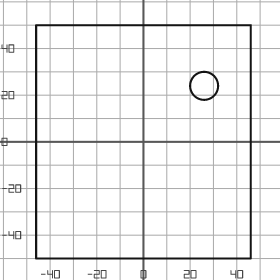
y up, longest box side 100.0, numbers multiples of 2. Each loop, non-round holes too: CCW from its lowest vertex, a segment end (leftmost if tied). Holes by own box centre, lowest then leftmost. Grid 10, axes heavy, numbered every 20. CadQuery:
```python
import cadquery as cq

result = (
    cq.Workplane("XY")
    .moveTo(-46.0, -50.0)
    .lineTo(46.0, -50.0)
    .lineTo(46.0, 50.0)
    .lineTo(-46.0, 50.0)
    .close()
    .moveTo(26.0, 24.0)
    .circle(6.0)
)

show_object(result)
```